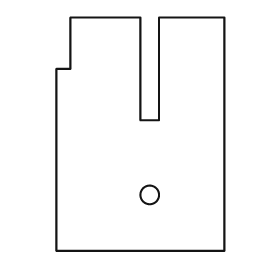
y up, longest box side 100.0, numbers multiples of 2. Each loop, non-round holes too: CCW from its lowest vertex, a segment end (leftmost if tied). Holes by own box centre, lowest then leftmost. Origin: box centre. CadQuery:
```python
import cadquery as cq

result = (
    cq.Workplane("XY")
    .moveTo(-36.0, -50.0)
    .lineTo(36.0, -50.0)
    .lineTo(36.0, 50.0)
    .lineTo(8.0, 50.0)
    .lineTo(8.0, 6.0)
    .lineTo(0.0, 6.0)
    .lineTo(0.0, 50.0)
    .lineTo(-30.0, 50.0)
    .lineTo(-30.0, 28.0)
    .lineTo(-36.0, 28.0)
    .close()
    .moveTo(4.0, -26.0)
    .circle(4.0)
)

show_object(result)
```